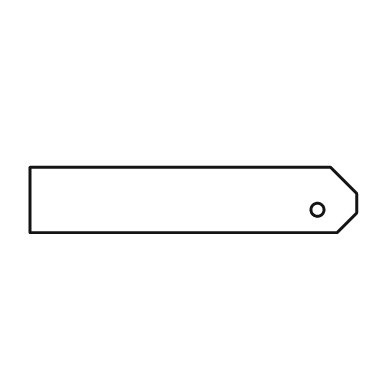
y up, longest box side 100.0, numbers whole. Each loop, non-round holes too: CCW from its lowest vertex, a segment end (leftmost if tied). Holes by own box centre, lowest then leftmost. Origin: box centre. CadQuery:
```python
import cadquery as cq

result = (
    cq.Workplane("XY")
    .moveTo(-50.0, -10.0)
    .lineTo(44.0, -10.0)
    .lineTo(50.0, -4.0)
    .lineTo(50.0, 2.0)
    .lineTo(42.0, 10.0)
    .lineTo(-50.0, 10.0)
    .close()
    .moveTo(38.0, -3.0)
    .circle(2.0)
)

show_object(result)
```